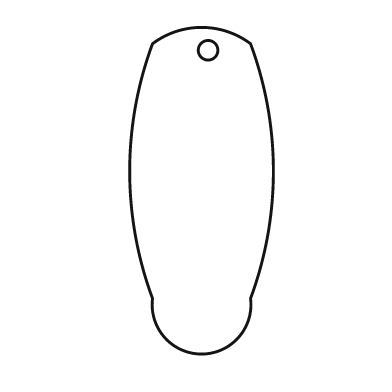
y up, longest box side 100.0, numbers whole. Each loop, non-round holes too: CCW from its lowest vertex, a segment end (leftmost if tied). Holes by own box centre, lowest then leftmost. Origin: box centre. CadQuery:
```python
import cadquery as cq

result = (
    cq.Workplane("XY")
    .moveTo(-15.0, -33.0)
    .threePointArc((0.0, -50.0), (15.0, -33.0))
    .threePointArc((22.0, 6.0), (15.0, 45.0))
    .threePointArc((0.0, 50.0), (-15.0, 45.0))
    .threePointArc((-22.0, 6.0), (-15.0, -33.0))
    .close()
    .moveTo(2.0, 43.0)
    .circle(3.0)
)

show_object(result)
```